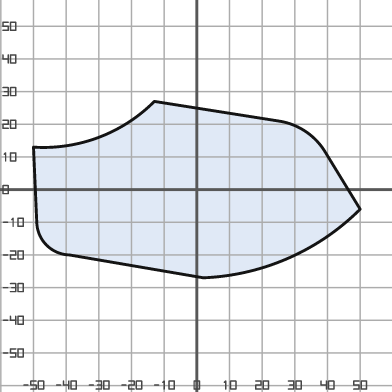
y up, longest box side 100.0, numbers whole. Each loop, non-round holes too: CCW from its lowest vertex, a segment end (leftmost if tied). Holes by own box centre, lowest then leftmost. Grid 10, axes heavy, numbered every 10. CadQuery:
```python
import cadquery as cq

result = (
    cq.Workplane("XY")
    .moveTo(2.0, -27.0)
    .threePointArc((28.0, -21.0), (50.0, -6.0))
    .lineTo(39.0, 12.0)
    .threePointArc((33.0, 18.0), (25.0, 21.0))
    .lineTo(-13.0, 27.0)
    .threePointArc((-30.0, 16.0), (-50.0, 13.0))
    .lineTo(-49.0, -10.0)
    .threePointArc((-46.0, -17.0), (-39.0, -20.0))
    .close()
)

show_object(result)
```